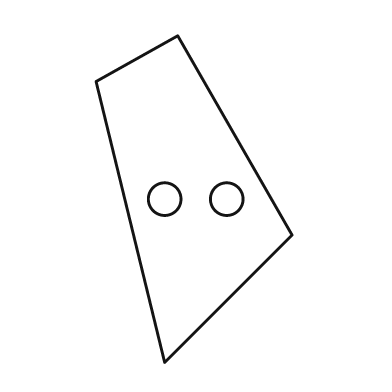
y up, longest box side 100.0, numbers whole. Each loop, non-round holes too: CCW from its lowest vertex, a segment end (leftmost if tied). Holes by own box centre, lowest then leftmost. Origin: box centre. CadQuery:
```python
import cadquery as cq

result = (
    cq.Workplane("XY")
    .moveTo(-9.0, -50.0)
    .lineTo(30.0, -11.0)
    .lineTo(-5.0, 50.0)
    .lineTo(-30.0, 36.0)
    .close()
    .moveTo(-9.0, 0.0)
    .circle(5.0)
    .moveTo(10.0, 0.0)
    .circle(5.0)
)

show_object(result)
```